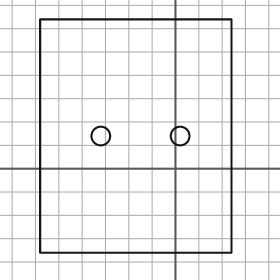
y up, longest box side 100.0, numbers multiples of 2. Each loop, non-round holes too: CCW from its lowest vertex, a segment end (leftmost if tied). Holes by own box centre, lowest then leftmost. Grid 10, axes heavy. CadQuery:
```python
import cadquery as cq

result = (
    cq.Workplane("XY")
    .moveTo(-58.0, -36.0)
    .lineTo(24.0, -36.0)
    .lineTo(24.0, 64.0)
    .lineTo(-58.0, 64.0)
    .close()
    .moveTo(-32.0, 14.0)
    .circle(4.0)
    .moveTo(2.0, 14.0)
    .circle(4.0)
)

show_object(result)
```